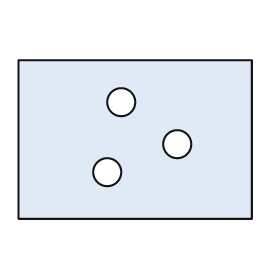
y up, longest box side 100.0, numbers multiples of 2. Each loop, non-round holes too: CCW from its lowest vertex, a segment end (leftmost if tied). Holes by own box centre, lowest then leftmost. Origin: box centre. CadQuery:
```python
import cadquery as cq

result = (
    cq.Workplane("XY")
    .moveTo(-50.0, -34.0)
    .lineTo(50.0, -34.0)
    .lineTo(50.0, 34.0)
    .lineTo(-50.0, 34.0)
    .close()
    .moveTo(-12.0, -14.0)
    .circle(6.0)
    .moveTo(18.0, -2.0)
    .circle(6.0)
    .moveTo(-6.0, 16.0)
    .circle(6.0)
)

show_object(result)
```